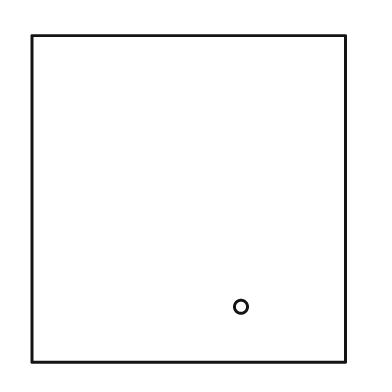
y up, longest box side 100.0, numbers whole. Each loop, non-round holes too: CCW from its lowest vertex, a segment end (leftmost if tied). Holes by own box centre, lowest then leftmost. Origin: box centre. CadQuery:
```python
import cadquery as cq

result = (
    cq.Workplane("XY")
    .moveTo(-48.0, -50.0)
    .lineTo(48.0, -50.0)
    .lineTo(48.0, 50.0)
    .lineTo(-48.0, 50.0)
    .close()
    .moveTo(16.0, -33.0)
    .circle(2.0)
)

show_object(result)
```